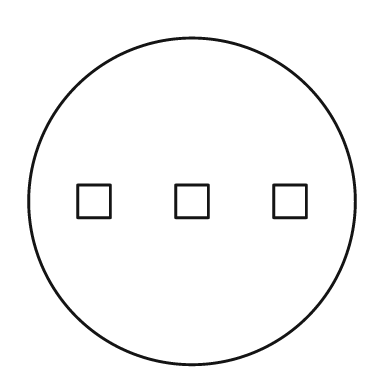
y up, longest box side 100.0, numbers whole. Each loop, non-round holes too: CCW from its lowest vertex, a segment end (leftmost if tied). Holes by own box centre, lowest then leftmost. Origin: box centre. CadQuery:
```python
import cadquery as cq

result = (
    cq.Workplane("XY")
    .moveTo(0.0, 0.0)
    .circle(50.0)
    .moveTo(-35.0, -5.0)
    .lineTo(-25.0, -5.0)
    .lineTo(-25.0, 5.0)
    .lineTo(-35.0, 5.0)
    .close()
    .moveTo(-5.0, -5.0)
    .lineTo(5.0, -5.0)
    .lineTo(5.0, 5.0)
    .lineTo(-5.0, 5.0)
    .close()
    .moveTo(25.0, -5.0)
    .lineTo(35.0, -5.0)
    .lineTo(35.0, 5.0)
    .lineTo(25.0, 5.0)
    .close()
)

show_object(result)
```